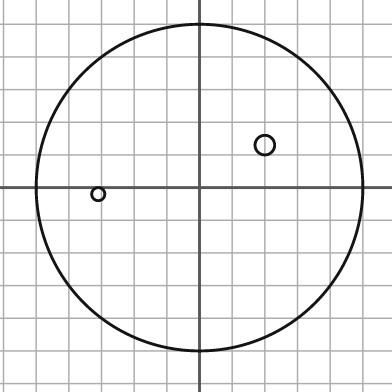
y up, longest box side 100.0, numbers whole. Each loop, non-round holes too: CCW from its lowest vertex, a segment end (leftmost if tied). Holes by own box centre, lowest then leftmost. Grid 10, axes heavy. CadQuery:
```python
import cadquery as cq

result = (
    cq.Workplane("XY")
    .moveTo(0.0, 0.0)
    .circle(50.0)
    .moveTo(-31.0, -2.0)
    .circle(2.0)
    .moveTo(20.0, 13.0)
    .circle(3.0)
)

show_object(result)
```